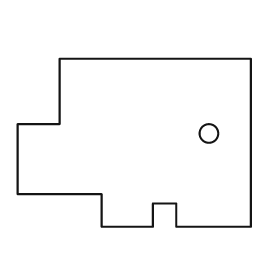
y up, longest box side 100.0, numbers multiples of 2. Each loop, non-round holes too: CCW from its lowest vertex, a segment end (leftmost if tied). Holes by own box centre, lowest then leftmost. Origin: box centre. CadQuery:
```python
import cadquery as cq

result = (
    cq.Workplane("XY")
    .moveTo(-14.0, -36.0)
    .lineTo(8.0, -36.0)
    .lineTo(8.0, -26.0)
    .lineTo(18.0, -26.0)
    .lineTo(18.0, -36.0)
    .lineTo(50.0, -36.0)
    .lineTo(50.0, 36.0)
    .lineTo(-32.0, 36.0)
    .lineTo(-32.0, 8.0)
    .lineTo(-50.0, 8.0)
    .lineTo(-50.0, -22.0)
    .lineTo(-14.0, -22.0)
    .close()
    .moveTo(32.0, 4.0)
    .circle(4.0)
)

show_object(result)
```